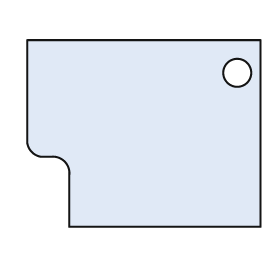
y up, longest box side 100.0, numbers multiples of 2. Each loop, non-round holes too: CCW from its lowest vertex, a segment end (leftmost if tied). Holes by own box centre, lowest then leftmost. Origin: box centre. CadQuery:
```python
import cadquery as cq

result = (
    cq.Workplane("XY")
    .moveTo(-32.0, -40.0)
    .lineTo(50.0, -40.0)
    .lineTo(50.0, 40.0)
    .lineTo(-50.0, 40.0)
    .lineTo(-50.0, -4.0)
    .threePointArc((-48.0, -8.0), (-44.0, -10.0))
    .lineTo(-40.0, -10.0)
    .threePointArc((-34.0, -12.0), (-32.0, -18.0))
    .close()
    .moveTo(40.0, 26.0)
    .circle(6.0)
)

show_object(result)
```